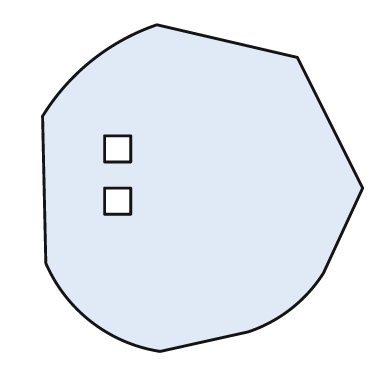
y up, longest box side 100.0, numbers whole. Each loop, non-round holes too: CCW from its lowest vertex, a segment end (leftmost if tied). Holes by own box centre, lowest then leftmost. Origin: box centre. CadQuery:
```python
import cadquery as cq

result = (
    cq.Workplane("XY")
    .moveTo(-13.0, -50.0)
    .lineTo(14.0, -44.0)
    .threePointArc((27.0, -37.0), (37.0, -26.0))
    .lineTo(49.0, 0.0)
    .lineTo(29.0, 40.0)
    .lineTo(-14.0, 50.0)
    .threePointArc((-34.0, 39.0), (-49.0, 22.0))
    .lineTo(-48.0, -23.0)
    .threePointArc((-34.0, -41.0), (-13.0, -50.0))
    .close()
    .moveTo(-30.0, -8.0)
    .lineTo(-22.0, -8.0)
    .lineTo(-22.0, 0.0)
    .lineTo(-30.0, 0.0)
    .close()
    .moveTo(-30.0, 8.0)
    .lineTo(-22.0, 8.0)
    .lineTo(-22.0, 16.0)
    .lineTo(-30.0, 16.0)
    .close()
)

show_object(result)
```